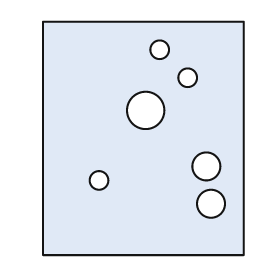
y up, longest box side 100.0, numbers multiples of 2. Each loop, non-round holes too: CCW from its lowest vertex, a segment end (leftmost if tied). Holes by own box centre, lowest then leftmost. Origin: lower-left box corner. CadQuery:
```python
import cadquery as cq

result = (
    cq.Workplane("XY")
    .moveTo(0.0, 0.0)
    .lineTo(86.0, 0.0)
    .lineTo(86.0, 100.0)
    .lineTo(0.0, 100.0)
    .close()
    .moveTo(72.0, 22.0)
    .circle(6.0)
    .moveTo(24.0, 32.0)
    .circle(4.0)
    .moveTo(70.0, 38.0)
    .circle(6.0)
    .moveTo(44.0, 62.0)
    .circle(8.0)
    .moveTo(62.0, 76.0)
    .circle(4.0)
    .moveTo(50.0, 88.0)
    .circle(4.0)
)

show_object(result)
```